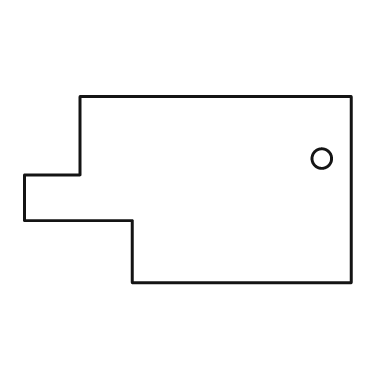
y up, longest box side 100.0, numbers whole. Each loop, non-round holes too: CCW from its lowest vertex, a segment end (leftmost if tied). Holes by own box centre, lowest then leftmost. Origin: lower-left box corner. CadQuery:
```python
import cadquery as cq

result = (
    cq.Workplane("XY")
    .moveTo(33.0, 0.0)
    .lineTo(100.0, 0.0)
    .lineTo(100.0, 57.0)
    .lineTo(17.0, 57.0)
    .lineTo(17.0, 33.0)
    .lineTo(0.0, 33.0)
    .lineTo(0.0, 19.0)
    .lineTo(33.0, 19.0)
    .close()
    .moveTo(91.0, 38.0)
    .circle(3.0)
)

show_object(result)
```